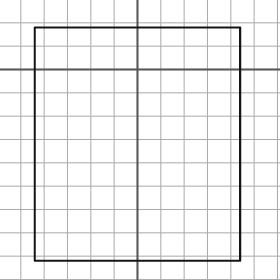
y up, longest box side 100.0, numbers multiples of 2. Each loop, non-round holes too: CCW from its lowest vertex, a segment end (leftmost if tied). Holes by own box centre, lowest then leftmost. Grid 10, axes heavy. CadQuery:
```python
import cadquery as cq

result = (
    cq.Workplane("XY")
    .moveTo(-44.0, -82.0)
    .lineTo(44.0, -82.0)
    .lineTo(44.0, 18.0)
    .lineTo(-44.0, 18.0)
    .close()
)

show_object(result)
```